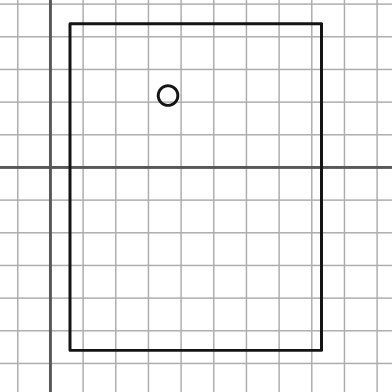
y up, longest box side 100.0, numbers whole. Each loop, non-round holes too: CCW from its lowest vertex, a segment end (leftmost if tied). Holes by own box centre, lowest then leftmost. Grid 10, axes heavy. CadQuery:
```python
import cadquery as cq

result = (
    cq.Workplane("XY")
    .moveTo(6.0, -56.0)
    .lineTo(83.0, -56.0)
    .lineTo(83.0, 44.0)
    .lineTo(6.0, 44.0)
    .close()
    .moveTo(36.0, 22.0)
    .circle(3.0)
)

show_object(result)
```